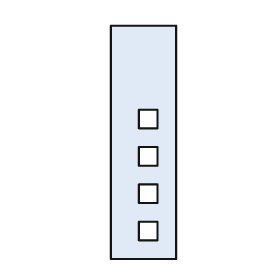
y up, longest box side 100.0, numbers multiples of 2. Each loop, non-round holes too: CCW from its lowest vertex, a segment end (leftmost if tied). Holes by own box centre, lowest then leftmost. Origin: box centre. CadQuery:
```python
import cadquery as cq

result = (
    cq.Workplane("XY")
    .moveTo(-14.0, -50.0)
    .lineTo(14.0, -50.0)
    .lineTo(14.0, 50.0)
    .lineTo(-14.0, 50.0)
    .close()
    .moveTo(-2.0, -42.0)
    .lineTo(6.0, -42.0)
    .lineTo(6.0, -34.0)
    .lineTo(-2.0, -34.0)
    .close()
    .moveTo(-2.0, -26.0)
    .lineTo(6.0, -26.0)
    .lineTo(6.0, -18.0)
    .lineTo(-2.0, -18.0)
    .close()
    .moveTo(-2.0, -10.0)
    .lineTo(6.0, -10.0)
    .lineTo(6.0, -2.0)
    .lineTo(-2.0, -2.0)
    .close()
    .moveTo(-2.0, 6.0)
    .lineTo(6.0, 6.0)
    .lineTo(6.0, 14.0)
    .lineTo(-2.0, 14.0)
    .close()
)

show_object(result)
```